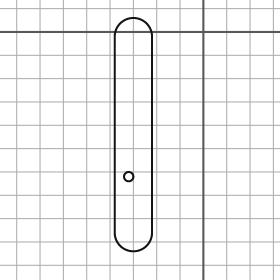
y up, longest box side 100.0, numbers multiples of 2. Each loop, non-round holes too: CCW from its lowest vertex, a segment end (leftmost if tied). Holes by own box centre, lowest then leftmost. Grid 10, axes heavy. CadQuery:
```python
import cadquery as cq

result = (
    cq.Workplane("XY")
    .moveTo(-38.0, -86.0)
    .threePointArc((-30.0, -94.0), (-22.0, -86.0))
    .lineTo(-22.0, -2.0)
    .threePointArc((-30.0, 6.0), (-38.0, -2.0))
    .close()
    .moveTo(-32.0, -62.0)
    .circle(2.0)
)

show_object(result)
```